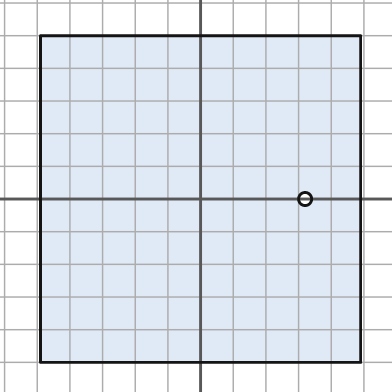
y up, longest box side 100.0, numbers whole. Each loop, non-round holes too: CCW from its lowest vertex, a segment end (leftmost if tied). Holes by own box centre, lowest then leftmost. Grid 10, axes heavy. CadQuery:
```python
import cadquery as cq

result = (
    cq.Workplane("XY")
    .moveTo(-49.0, -50.0)
    .lineTo(49.0, -50.0)
    .lineTo(49.0, 50.0)
    .lineTo(-49.0, 50.0)
    .close()
    .moveTo(32.0, 0.0)
    .circle(2.0)
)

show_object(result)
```